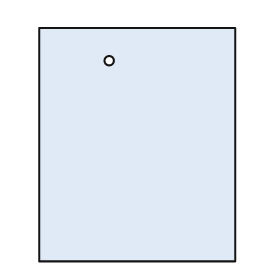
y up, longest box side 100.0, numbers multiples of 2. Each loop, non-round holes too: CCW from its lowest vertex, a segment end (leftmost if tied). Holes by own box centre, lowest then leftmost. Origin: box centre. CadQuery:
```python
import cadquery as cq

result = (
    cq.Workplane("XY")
    .moveTo(-42.0, -50.0)
    .lineTo(42.0, -50.0)
    .lineTo(42.0, 50.0)
    .lineTo(-42.0, 50.0)
    .close()
    .moveTo(-12.0, 36.0)
    .circle(2.0)
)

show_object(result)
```